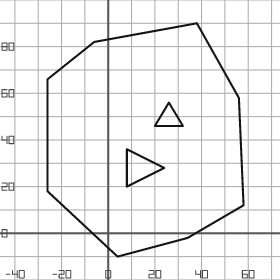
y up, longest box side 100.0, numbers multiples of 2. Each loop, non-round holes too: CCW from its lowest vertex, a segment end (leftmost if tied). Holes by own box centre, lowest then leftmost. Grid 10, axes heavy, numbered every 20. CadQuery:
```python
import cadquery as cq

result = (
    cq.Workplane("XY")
    .moveTo(4.0, -10.0)
    .lineTo(34.0, -2.0)
    .lineTo(58.0, 12.0)
    .lineTo(56.0, 58.0)
    .lineTo(38.0, 90.0)
    .lineTo(-6.0, 82.0)
    .lineTo(-26.0, 66.0)
    .lineTo(-26.0, 18.0)
    .close()
    .moveTo(8.0, 20.0)
    .lineTo(24.0, 28.0)
    .lineTo(8.0, 36.0)
    .close()
    .moveTo(20.0, 46.0)
    .lineTo(32.0, 46.0)
    .lineTo(26.0, 56.0)
    .close()
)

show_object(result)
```